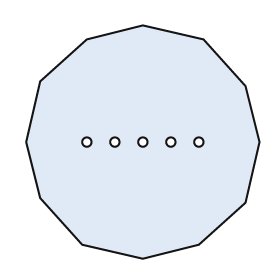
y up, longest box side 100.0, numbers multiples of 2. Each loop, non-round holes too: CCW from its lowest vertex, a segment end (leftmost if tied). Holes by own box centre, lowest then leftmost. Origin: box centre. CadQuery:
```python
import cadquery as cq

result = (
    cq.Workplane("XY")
    .moveTo(0.0, -50.0)
    .lineTo(24.0, -44.0)
    .lineTo(44.0, -26.0)
    .lineTo(50.0, 0.0)
    .lineTo(44.0, 24.0)
    .lineTo(26.0, 44.0)
    .lineTo(0.0, 50.0)
    .lineTo(-24.0, 44.0)
    .lineTo(-44.0, 26.0)
    .lineTo(-50.0, 0.0)
    .lineTo(-44.0, -24.0)
    .lineTo(-26.0, -44.0)
    .close()
    .moveTo(-24.0, 0.0)
    .circle(2.0)
    .moveTo(-12.0, 0.0)
    .circle(2.0)
    .moveTo(0.0, 0.0)
    .circle(2.0)
    .moveTo(12.0, 0.0)
    .circle(2.0)
    .moveTo(24.0, 0.0)
    .circle(2.0)
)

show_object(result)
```